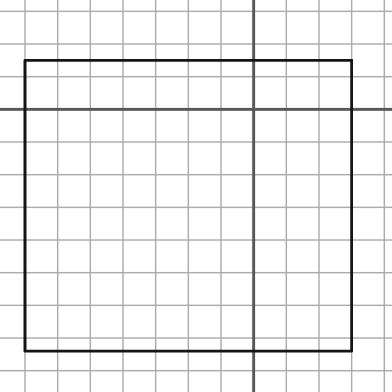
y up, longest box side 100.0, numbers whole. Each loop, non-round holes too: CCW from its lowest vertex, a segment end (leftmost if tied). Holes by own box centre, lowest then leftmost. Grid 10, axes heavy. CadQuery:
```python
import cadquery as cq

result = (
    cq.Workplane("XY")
    .moveTo(-70.0, -74.0)
    .lineTo(30.0, -74.0)
    .lineTo(30.0, 15.0)
    .lineTo(-70.0, 15.0)
    .close()
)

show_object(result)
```